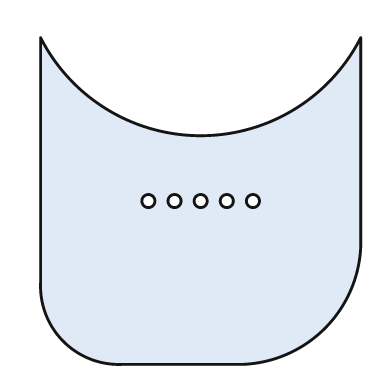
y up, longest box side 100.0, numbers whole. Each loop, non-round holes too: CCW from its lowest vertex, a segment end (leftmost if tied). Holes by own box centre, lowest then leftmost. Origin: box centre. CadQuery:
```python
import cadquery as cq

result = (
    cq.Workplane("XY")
    .moveTo(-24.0, -50.0)
    .lineTo(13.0, -50.0)
    .threePointArc((38.0, -39.0), (49.0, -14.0))
    .lineTo(49.0, 50.0)
    .threePointArc((0.0, 20.0), (-49.0, 50.0))
    .lineTo(-49.0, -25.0)
    .threePointArc((-42.0, -43.0), (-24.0, -50.0))
    .close()
    .moveTo(-16.0, 0.0)
    .circle(2.0)
    .moveTo(-8.0, 0.0)
    .circle(2.0)
    .moveTo(0.0, 0.0)
    .circle(2.0)
    .moveTo(8.0, 0.0)
    .circle(2.0)
    .moveTo(16.0, 0.0)
    .circle(2.0)
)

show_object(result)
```